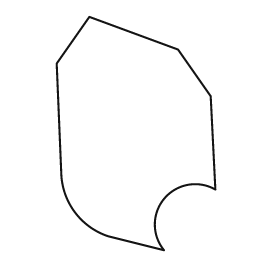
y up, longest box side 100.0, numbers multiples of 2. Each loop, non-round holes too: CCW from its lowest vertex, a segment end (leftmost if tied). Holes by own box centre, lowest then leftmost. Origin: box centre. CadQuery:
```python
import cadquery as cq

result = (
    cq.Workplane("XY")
    .moveTo(12.0, -50.0)
    .threePointArc((12.0, -28.0), (34.0, -24.0))
    .lineTo(32.0, 16.0)
    .lineTo(18.0, 36.0)
    .lineTo(-20.0, 50.0)
    .lineTo(-34.0, 30.0)
    .lineTo(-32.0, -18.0)
    .threePointArc((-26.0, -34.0), (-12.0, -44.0))
    .close()
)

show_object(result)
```